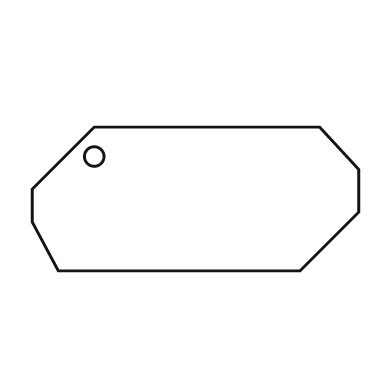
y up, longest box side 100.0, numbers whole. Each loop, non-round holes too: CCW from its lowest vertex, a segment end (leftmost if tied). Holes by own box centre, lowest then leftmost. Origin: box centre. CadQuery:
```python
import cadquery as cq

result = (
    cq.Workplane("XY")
    .moveTo(-42.0, -22.0)
    .lineTo(32.0, -22.0)
    .lineTo(50.0, -4.0)
    .lineTo(50.0, 9.0)
    .lineTo(38.0, 22.0)
    .lineTo(-31.0, 22.0)
    .lineTo(-50.0, 3.0)
    .lineTo(-50.0, -7.0)
    .close()
    .moveTo(-31.0, 13.0)
    .circle(3.0)
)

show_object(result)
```